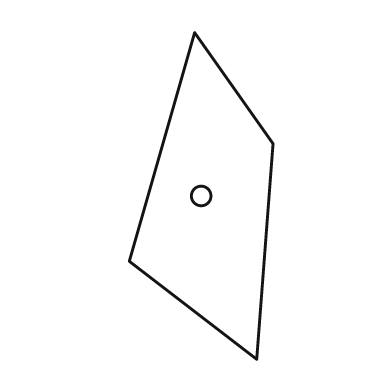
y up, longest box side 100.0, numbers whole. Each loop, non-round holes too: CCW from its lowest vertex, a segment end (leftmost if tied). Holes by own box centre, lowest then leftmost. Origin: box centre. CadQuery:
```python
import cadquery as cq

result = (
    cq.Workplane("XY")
    .moveTo(17.0, -50.0)
    .lineTo(22.0, 16.0)
    .lineTo(-2.0, 50.0)
    .lineTo(-22.0, -20.0)
    .close()
    .moveTo(0.0, 0.0)
    .circle(3.0)
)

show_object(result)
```